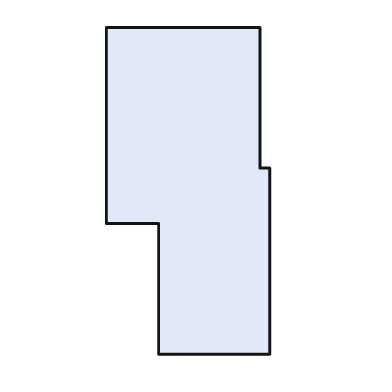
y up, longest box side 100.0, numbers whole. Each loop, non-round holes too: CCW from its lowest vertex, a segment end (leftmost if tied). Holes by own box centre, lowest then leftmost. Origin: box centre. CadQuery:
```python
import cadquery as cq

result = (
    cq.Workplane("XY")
    .moveTo(-9.0, -50.0)
    .lineTo(25.0, -50.0)
    .lineTo(25.0, 7.0)
    .lineTo(22.0, 7.0)
    .lineTo(22.0, 50.0)
    .lineTo(-25.0, 50.0)
    .lineTo(-25.0, -10.0)
    .lineTo(-9.0, -10.0)
    .close()
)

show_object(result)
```